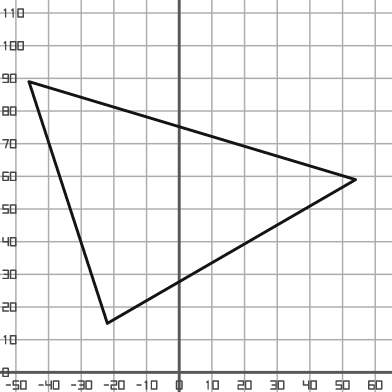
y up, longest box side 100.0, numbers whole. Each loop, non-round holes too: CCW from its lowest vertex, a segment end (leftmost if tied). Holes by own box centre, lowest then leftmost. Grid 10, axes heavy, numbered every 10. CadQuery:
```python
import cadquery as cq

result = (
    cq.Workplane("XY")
    .moveTo(-22.0, 15.0)
    .lineTo(54.0, 59.0)
    .lineTo(-46.0, 89.0)
    .close()
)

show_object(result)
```